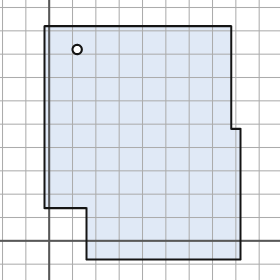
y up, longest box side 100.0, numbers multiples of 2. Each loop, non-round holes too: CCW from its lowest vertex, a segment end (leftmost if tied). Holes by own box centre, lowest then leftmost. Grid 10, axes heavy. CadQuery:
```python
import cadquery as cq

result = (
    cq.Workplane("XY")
    .moveTo(16.0, -8.0)
    .lineTo(82.0, -8.0)
    .lineTo(82.0, 48.0)
    .lineTo(78.0, 48.0)
    .lineTo(78.0, 92.0)
    .lineTo(-2.0, 92.0)
    .lineTo(-2.0, 14.0)
    .lineTo(16.0, 14.0)
    .close()
    .moveTo(12.0, 82.0)
    .circle(2.0)
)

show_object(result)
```